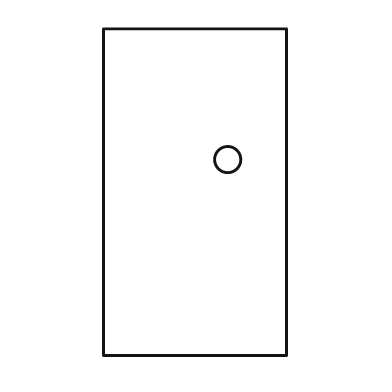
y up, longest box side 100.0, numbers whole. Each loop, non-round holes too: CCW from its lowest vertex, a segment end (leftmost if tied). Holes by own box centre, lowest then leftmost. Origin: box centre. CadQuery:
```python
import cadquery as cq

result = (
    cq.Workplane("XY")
    .moveTo(-28.0, -50.0)
    .lineTo(28.0, -50.0)
    .lineTo(28.0, 50.0)
    .lineTo(-28.0, 50.0)
    .close()
    .moveTo(10.0, 10.0)
    .circle(4.0)
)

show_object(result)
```